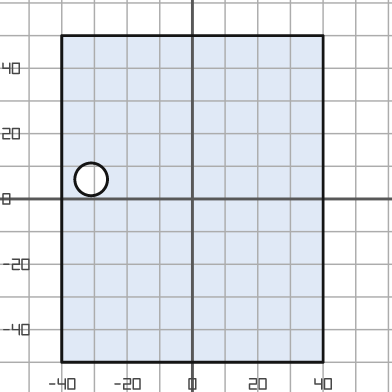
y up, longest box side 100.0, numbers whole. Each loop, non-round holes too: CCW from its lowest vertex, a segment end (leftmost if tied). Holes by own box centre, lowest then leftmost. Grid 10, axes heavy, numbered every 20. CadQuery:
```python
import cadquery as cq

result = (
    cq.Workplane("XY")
    .moveTo(-40.0, -50.0)
    .lineTo(40.0, -50.0)
    .lineTo(40.0, 50.0)
    .lineTo(-40.0, 50.0)
    .close()
    .moveTo(-31.0, 6.0)
    .circle(5.0)
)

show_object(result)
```